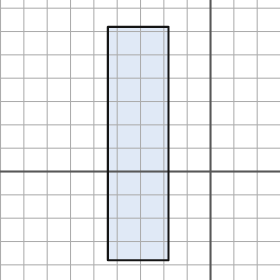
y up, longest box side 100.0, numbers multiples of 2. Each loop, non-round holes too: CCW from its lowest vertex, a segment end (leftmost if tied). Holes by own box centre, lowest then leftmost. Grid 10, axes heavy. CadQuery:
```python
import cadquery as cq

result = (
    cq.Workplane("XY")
    .moveTo(-44.0, -38.0)
    .lineTo(-18.0, -38.0)
    .lineTo(-18.0, 62.0)
    .lineTo(-44.0, 62.0)
    .close()
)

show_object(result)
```